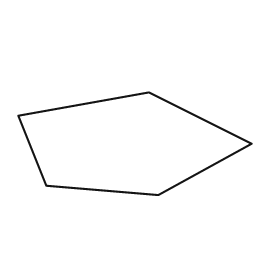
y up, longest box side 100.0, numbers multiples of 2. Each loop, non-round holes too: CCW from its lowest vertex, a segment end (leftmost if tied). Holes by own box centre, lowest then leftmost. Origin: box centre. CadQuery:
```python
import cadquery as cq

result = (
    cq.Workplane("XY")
    .moveTo(10.0, -22.0)
    .lineTo(50.0, 0.0)
    .lineTo(6.0, 22.0)
    .lineTo(-50.0, 12.0)
    .lineTo(-38.0, -18.0)
    .close()
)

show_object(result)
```